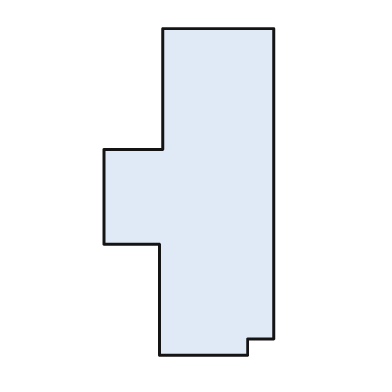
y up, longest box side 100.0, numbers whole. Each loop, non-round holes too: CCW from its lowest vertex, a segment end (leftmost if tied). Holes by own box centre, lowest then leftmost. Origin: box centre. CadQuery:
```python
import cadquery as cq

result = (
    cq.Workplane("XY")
    .moveTo(-9.0, -50.0)
    .lineTo(18.0, -50.0)
    .lineTo(18.0, -45.0)
    .lineTo(26.0, -45.0)
    .lineTo(26.0, 50.0)
    .lineTo(-8.0, 50.0)
    .lineTo(-8.0, 13.0)
    .lineTo(-26.0, 13.0)
    .lineTo(-26.0, -16.0)
    .lineTo(-9.0, -16.0)
    .close()
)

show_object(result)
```